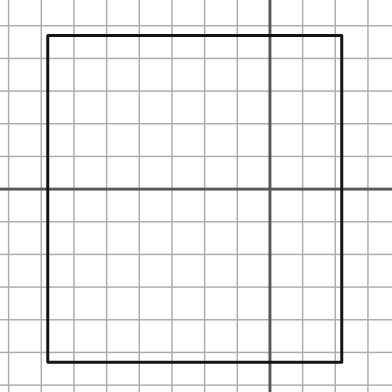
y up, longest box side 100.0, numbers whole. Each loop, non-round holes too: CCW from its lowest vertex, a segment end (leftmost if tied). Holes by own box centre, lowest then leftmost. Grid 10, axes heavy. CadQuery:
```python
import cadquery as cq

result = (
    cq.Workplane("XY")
    .moveTo(-68.0, -53.0)
    .lineTo(22.0, -53.0)
    .lineTo(22.0, 47.0)
    .lineTo(-68.0, 47.0)
    .close()
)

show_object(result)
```